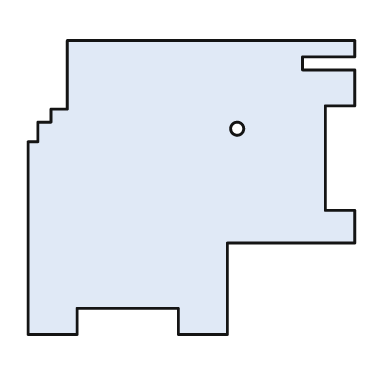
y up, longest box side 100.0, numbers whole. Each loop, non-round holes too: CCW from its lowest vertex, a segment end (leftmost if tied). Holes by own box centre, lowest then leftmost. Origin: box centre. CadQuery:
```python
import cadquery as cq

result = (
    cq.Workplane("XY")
    .moveTo(-50.0, -45.0)
    .lineTo(-35.0, -45.0)
    .lineTo(-35.0, -37.0)
    .lineTo(-4.0, -37.0)
    .lineTo(-4.0, -45.0)
    .lineTo(11.0, -45.0)
    .lineTo(11.0, -17.0)
    .lineTo(50.0, -17.0)
    .lineTo(50.0, -7.0)
    .lineTo(41.0, -7.0)
    .lineTo(41.0, 25.0)
    .lineTo(50.0, 25.0)
    .lineTo(50.0, 36.0)
    .lineTo(34.0, 36.0)
    .lineTo(34.0, 40.0)
    .lineTo(50.0, 40.0)
    .lineTo(50.0, 45.0)
    .lineTo(-38.0, 45.0)
    .lineTo(-38.0, 24.0)
    .lineTo(-43.0, 24.0)
    .lineTo(-43.0, 20.0)
    .lineTo(-47.0, 20.0)
    .lineTo(-47.0, 14.0)
    .lineTo(-50.0, 14.0)
    .close()
    .moveTo(14.0, 18.0)
    .circle(2.0)
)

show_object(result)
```